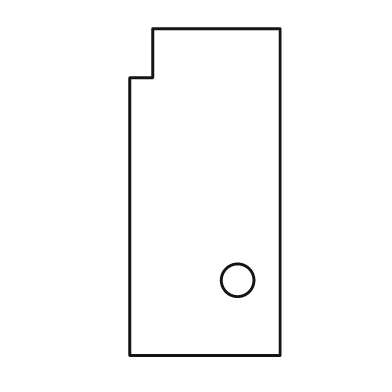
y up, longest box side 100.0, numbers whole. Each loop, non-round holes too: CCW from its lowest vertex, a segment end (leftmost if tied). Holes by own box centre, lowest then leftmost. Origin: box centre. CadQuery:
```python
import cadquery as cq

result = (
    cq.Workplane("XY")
    .moveTo(-23.0, -50.0)
    .lineTo(23.0, -50.0)
    .lineTo(23.0, 50.0)
    .lineTo(-16.0, 50.0)
    .lineTo(-16.0, 35.0)
    .lineTo(-23.0, 35.0)
    .close()
    .moveTo(10.0, -27.0)
    .circle(5.0)
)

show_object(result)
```